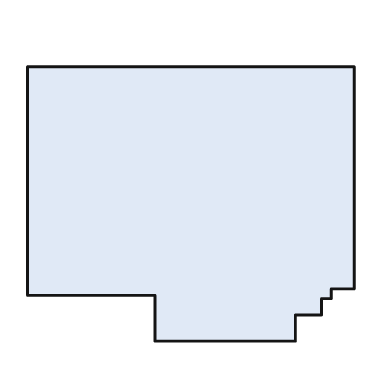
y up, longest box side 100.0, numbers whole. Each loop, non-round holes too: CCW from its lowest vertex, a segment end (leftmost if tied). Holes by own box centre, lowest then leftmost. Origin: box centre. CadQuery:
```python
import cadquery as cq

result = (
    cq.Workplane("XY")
    .moveTo(-11.0, -42.0)
    .lineTo(32.0, -42.0)
    .lineTo(32.0, -34.0)
    .lineTo(40.0, -34.0)
    .lineTo(40.0, -29.0)
    .lineTo(43.0, -29.0)
    .lineTo(43.0, -26.0)
    .lineTo(50.0, -26.0)
    .lineTo(50.0, 42.0)
    .lineTo(-50.0, 42.0)
    .lineTo(-50.0, -28.0)
    .lineTo(-11.0, -28.0)
    .close()
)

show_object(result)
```